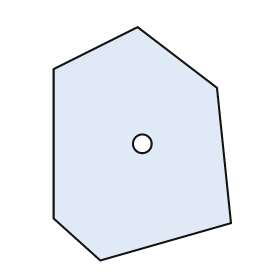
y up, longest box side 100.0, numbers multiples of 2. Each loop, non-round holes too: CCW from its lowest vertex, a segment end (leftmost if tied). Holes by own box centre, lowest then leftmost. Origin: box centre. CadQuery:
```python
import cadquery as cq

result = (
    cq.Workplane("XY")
    .moveTo(-18.0, -50.0)
    .lineTo(38.0, -34.0)
    .lineTo(32.0, 24.0)
    .lineTo(-2.0, 50.0)
    .lineTo(-38.0, 32.0)
    .lineTo(-38.0, -32.0)
    .close()
    .moveTo(0.0, 0.0)
    .circle(4.0)
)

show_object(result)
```